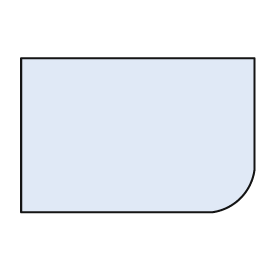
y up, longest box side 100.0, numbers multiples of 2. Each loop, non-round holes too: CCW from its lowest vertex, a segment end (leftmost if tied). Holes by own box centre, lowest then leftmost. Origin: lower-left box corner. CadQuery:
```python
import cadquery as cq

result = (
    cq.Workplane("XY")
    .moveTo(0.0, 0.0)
    .lineTo(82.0, 0.0)
    .threePointArc((94.0, 6.0), (100.0, 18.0))
    .lineTo(100.0, 66.0)
    .lineTo(0.0, 66.0)
    .close()
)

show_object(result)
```